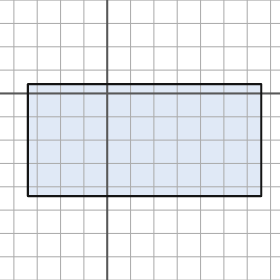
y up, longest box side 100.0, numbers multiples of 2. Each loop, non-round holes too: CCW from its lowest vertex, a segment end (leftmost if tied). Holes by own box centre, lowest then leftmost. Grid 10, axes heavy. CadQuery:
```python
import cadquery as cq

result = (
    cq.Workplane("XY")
    .moveTo(-34.0, -44.0)
    .lineTo(66.0, -44.0)
    .lineTo(66.0, 4.0)
    .lineTo(-34.0, 4.0)
    .close()
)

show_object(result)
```